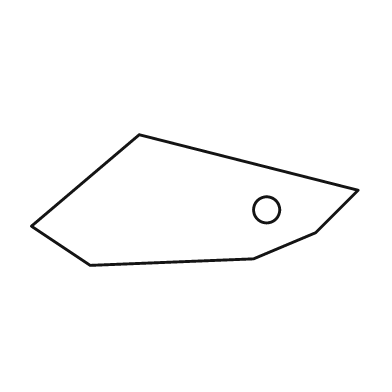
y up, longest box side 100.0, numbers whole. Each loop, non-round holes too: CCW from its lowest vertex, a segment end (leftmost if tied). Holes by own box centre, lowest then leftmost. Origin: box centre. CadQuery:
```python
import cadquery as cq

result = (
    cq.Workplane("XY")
    .moveTo(-32.0, -20.0)
    .lineTo(18.0, -18.0)
    .lineTo(37.0, -10.0)
    .lineTo(50.0, 3.0)
    .lineTo(-17.0, 20.0)
    .lineTo(-50.0, -8.0)
    .close()
    .moveTo(22.0, -3.0)
    .circle(4.0)
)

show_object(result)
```